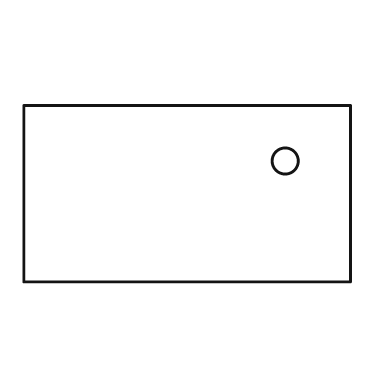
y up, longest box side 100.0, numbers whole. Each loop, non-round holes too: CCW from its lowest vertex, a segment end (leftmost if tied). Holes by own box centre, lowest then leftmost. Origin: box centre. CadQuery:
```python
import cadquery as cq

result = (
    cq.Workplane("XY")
    .moveTo(-50.0, -27.0)
    .lineTo(50.0, -27.0)
    .lineTo(50.0, 27.0)
    .lineTo(-50.0, 27.0)
    .close()
    .moveTo(30.0, 10.0)
    .circle(4.0)
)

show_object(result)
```